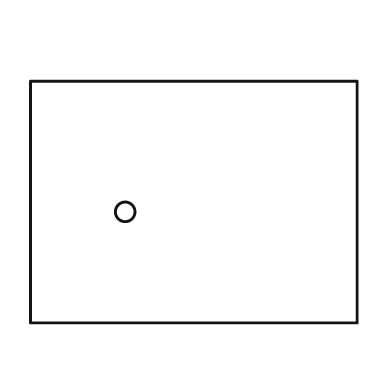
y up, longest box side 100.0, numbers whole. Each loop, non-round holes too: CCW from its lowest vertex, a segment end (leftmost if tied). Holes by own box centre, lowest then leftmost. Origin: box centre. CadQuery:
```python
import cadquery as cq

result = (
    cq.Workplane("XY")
    .moveTo(-50.0, -37.0)
    .lineTo(50.0, -37.0)
    .lineTo(50.0, 37.0)
    .lineTo(-50.0, 37.0)
    .close()
    .moveTo(-21.0, -3.0)
    .circle(3.0)
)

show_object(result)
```